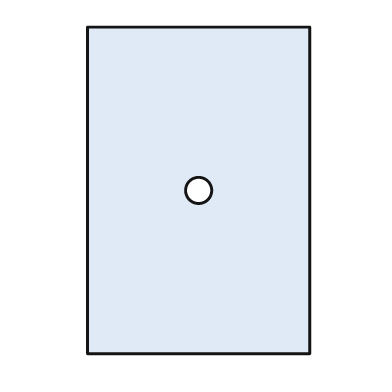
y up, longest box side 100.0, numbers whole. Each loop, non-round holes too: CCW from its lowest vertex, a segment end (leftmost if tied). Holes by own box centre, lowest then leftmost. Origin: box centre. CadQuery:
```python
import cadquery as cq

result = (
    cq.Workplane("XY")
    .moveTo(-34.0, -50.0)
    .lineTo(34.0, -50.0)
    .lineTo(34.0, 50.0)
    .lineTo(-34.0, 50.0)
    .close()
    .moveTo(0.0, 0.0)
    .circle(4.0)
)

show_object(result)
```